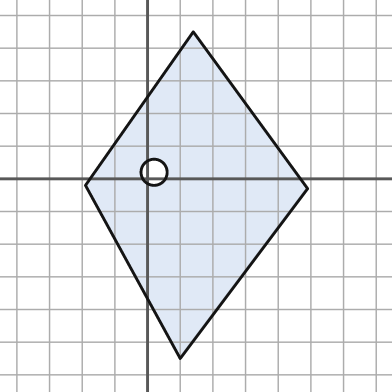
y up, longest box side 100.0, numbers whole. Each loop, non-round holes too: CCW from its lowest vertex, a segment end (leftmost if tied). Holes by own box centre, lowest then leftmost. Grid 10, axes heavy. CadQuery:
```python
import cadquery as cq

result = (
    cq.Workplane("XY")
    .moveTo(10.0, -55.0)
    .lineTo(49.0, -3.0)
    .lineTo(14.0, 45.0)
    .lineTo(-19.0, -2.0)
    .close()
    .moveTo(2.0, 2.0)
    .circle(4.0)
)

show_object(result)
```